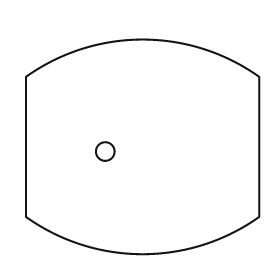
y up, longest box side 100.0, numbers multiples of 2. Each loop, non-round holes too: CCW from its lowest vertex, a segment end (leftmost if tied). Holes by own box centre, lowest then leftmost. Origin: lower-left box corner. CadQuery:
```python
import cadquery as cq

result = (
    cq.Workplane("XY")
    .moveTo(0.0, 16.0)
    .threePointArc((50.0, 0.0), (100.0, 16.0))
    .lineTo(100.0, 76.0)
    .threePointArc((50.0, 92.0), (0.0, 76.0))
    .close()
    .moveTo(34.0, 44.0)
    .circle(4.0)
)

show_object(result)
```